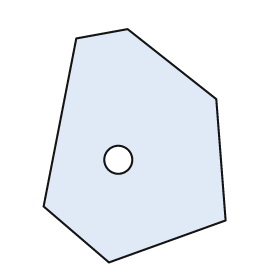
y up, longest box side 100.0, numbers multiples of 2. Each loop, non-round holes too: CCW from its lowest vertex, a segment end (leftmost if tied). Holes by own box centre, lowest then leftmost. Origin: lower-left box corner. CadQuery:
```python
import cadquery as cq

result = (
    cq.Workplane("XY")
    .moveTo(28.0, 0.0)
    .lineTo(78.0, 18.0)
    .lineTo(74.0, 70.0)
    .lineTo(36.0, 100.0)
    .lineTo(14.0, 96.0)
    .lineTo(0.0, 24.0)
    .close()
    .moveTo(32.0, 44.0)
    .circle(6.0)
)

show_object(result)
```